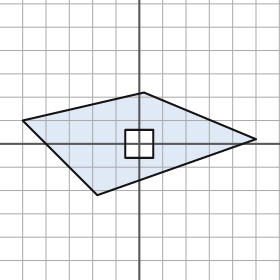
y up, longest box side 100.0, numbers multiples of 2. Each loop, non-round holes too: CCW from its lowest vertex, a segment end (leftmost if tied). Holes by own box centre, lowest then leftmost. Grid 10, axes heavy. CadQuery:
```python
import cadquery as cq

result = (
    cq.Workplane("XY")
    .moveTo(-18.0, -22.0)
    .lineTo(50.0, 2.0)
    .lineTo(2.0, 22.0)
    .lineTo(-50.0, 10.0)
    .close()
    .moveTo(-6.0, -6.0)
    .lineTo(6.0, -6.0)
    .lineTo(6.0, 6.0)
    .lineTo(-6.0, 6.0)
    .close()
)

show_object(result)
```